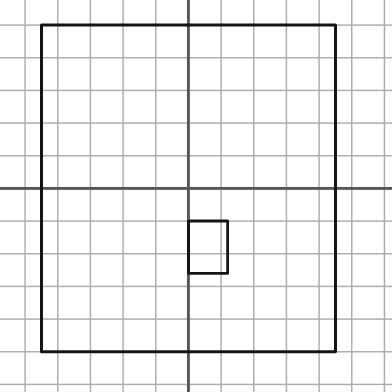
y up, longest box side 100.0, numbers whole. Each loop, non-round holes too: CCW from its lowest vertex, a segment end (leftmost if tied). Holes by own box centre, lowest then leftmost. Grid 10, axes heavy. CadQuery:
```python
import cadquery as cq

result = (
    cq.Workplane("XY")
    .moveTo(-45.0, -50.0)
    .lineTo(45.0, -50.0)
    .lineTo(45.0, 50.0)
    .lineTo(-45.0, 50.0)
    .close()
    .moveTo(0.0, -26.0)
    .lineTo(12.0, -26.0)
    .lineTo(12.0, -10.0)
    .lineTo(0.0, -10.0)
    .close()
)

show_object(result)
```